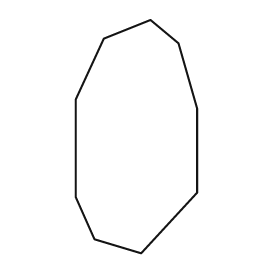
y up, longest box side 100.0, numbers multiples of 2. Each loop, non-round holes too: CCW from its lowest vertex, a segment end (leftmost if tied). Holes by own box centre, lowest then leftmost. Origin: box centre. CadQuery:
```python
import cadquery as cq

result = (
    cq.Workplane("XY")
    .moveTo(2.0, -50.0)
    .lineTo(26.0, -24.0)
    .lineTo(26.0, 12.0)
    .lineTo(18.0, 40.0)
    .lineTo(6.0, 50.0)
    .lineTo(-14.0, 42.0)
    .lineTo(-26.0, 16.0)
    .lineTo(-26.0, -26.0)
    .lineTo(-18.0, -44.0)
    .close()
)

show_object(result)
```